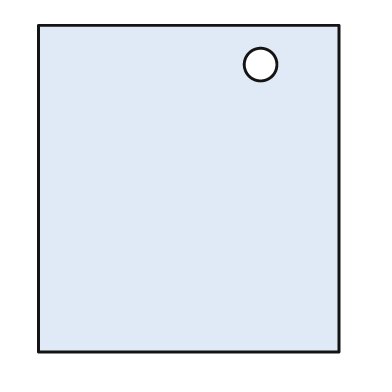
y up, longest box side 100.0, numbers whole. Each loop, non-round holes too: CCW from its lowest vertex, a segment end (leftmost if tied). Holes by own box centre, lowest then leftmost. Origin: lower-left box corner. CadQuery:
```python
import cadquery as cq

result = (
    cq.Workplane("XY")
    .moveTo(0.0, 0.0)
    .lineTo(92.0, 0.0)
    .lineTo(92.0, 100.0)
    .lineTo(0.0, 100.0)
    .close()
    .moveTo(68.0, 88.0)
    .circle(5.0)
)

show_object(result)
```